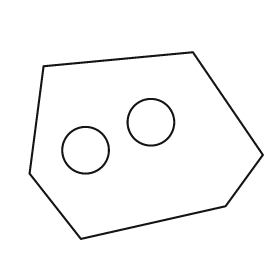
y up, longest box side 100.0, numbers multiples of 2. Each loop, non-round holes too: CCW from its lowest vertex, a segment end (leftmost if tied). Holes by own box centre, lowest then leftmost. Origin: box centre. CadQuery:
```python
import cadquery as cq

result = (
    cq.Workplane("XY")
    .moveTo(-28.0, -40.0)
    .lineTo(34.0, -26.0)
    .lineTo(50.0, -4.0)
    .lineTo(20.0, 40.0)
    .lineTo(-44.0, 34.0)
    .lineTo(-50.0, -12.0)
    .close()
    .moveTo(-26.0, -2.0)
    .circle(10.0)
    .moveTo(2.0, 10.0)
    .circle(10.0)
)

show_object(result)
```